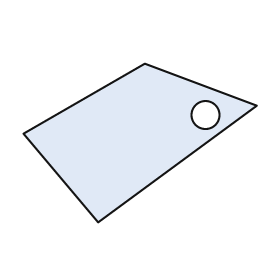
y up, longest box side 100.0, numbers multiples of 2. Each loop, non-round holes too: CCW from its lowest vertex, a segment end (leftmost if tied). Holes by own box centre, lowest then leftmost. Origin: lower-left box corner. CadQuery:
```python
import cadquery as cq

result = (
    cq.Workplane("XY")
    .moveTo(32.0, 0.0)
    .lineTo(100.0, 50.0)
    .lineTo(52.0, 68.0)
    .lineTo(0.0, 38.0)
    .close()
    .moveTo(78.0, 46.0)
    .circle(6.0)
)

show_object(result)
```